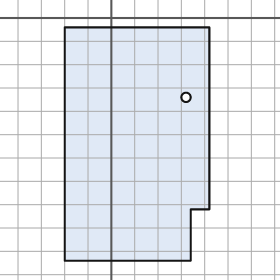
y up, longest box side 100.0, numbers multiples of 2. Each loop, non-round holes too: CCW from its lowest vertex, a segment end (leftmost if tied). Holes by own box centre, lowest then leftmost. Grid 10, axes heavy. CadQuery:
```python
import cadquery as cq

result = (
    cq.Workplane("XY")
    .moveTo(-20.0, -104.0)
    .lineTo(34.0, -104.0)
    .lineTo(34.0, -82.0)
    .lineTo(42.0, -82.0)
    .lineTo(42.0, -4.0)
    .lineTo(-20.0, -4.0)
    .close()
    .moveTo(32.0, -34.0)
    .circle(2.0)
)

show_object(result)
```